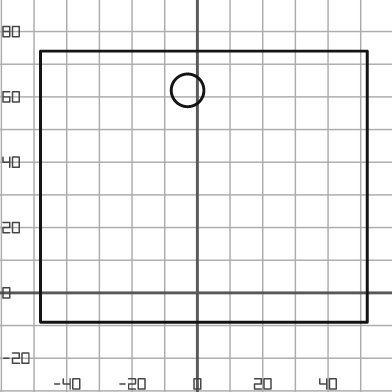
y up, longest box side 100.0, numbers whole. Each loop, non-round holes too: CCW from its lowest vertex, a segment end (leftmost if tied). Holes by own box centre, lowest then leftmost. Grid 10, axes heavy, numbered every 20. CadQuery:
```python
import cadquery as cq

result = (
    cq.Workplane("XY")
    .moveTo(-48.0, -9.0)
    .lineTo(52.0, -9.0)
    .lineTo(52.0, 74.0)
    .lineTo(-48.0, 74.0)
    .close()
    .moveTo(-3.0, 62.0)
    .circle(5.0)
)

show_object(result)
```